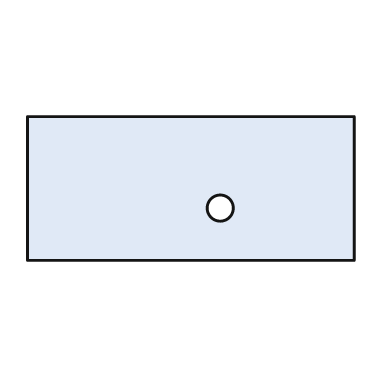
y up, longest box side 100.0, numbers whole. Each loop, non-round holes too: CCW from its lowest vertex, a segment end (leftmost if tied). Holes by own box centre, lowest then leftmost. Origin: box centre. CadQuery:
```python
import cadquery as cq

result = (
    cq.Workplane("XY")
    .moveTo(-50.0, -22.0)
    .lineTo(50.0, -22.0)
    .lineTo(50.0, 22.0)
    .lineTo(-50.0, 22.0)
    .close()
    .moveTo(9.0, -6.0)
    .circle(4.0)
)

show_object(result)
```